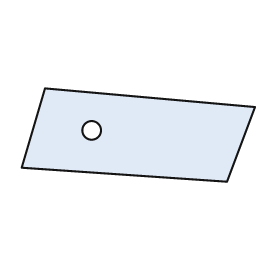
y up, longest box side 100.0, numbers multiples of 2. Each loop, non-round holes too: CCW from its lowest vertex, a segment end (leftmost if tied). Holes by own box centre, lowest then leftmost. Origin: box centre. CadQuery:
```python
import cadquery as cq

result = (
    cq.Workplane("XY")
    .moveTo(38.0, -20.0)
    .lineTo(50.0, 12.0)
    .lineTo(-40.0, 20.0)
    .lineTo(-50.0, -14.0)
    .close()
    .moveTo(-20.0, 2.0)
    .circle(4.0)
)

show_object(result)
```